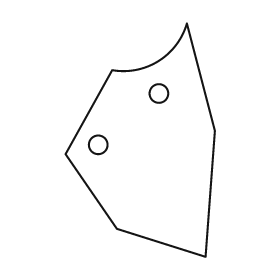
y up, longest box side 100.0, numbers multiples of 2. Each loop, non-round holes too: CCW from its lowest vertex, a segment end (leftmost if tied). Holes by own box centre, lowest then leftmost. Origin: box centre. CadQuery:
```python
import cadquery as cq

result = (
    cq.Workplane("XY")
    .moveTo(28.0, -50.0)
    .lineTo(32.0, 4.0)
    .lineTo(20.0, 50.0)
    .threePointArc((8.0, 34.0), (-12.0, 30.0))
    .lineTo(-32.0, -6.0)
    .lineTo(-10.0, -38.0)
    .close()
    .moveTo(-18.0, -2.0)
    .circle(4.0)
    .moveTo(8.0, 20.0)
    .circle(4.0)
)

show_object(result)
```